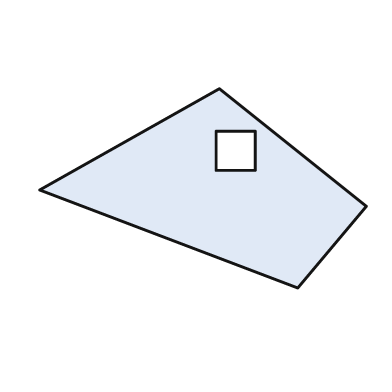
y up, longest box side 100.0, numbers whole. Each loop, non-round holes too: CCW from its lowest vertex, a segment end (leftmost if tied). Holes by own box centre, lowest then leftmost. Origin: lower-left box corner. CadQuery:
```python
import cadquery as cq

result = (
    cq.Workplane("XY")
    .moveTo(79.0, 0.0)
    .lineTo(100.0, 25.0)
    .lineTo(55.0, 61.0)
    .lineTo(0.0, 30.0)
    .close()
    .moveTo(54.0, 36.0)
    .lineTo(66.0, 36.0)
    .lineTo(66.0, 48.0)
    .lineTo(54.0, 48.0)
    .close()
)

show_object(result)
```